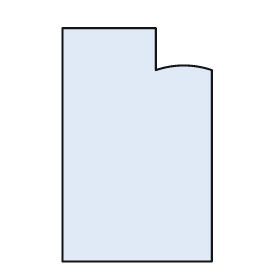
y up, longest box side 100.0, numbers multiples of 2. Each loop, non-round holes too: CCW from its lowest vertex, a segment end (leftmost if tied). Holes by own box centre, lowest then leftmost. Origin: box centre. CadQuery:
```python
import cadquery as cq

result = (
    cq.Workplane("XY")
    .moveTo(-32.0, -50.0)
    .lineTo(32.0, -50.0)
    .lineTo(32.0, 32.0)
    .threePointArc((20.0, 34.0), (8.0, 32.0))
    .lineTo(8.0, 50.0)
    .lineTo(-32.0, 50.0)
    .close()
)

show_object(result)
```